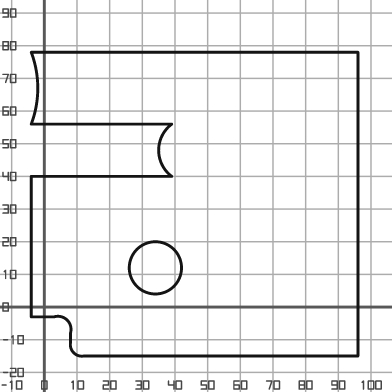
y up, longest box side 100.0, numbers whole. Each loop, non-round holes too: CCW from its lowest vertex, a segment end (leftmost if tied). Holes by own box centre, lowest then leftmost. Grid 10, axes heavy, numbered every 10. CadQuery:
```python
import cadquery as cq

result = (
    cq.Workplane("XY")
    .moveTo(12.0, -15.0)
    .lineTo(96.0, -15.0)
    .lineTo(96.0, 78.0)
    .lineTo(-4.0, 78.0)
    .threePointArc((-2.0, 67.0), (-4.0, 56.0))
    .lineTo(39.0, 56.0)
    .threePointArc((35.0, 48.0), (39.0, 40.0))
    .lineTo(-4.0, 40.0)
    .lineTo(-4.0, -3.0)
    .lineTo(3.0, -3.0)
    .threePointArc((7.0, -4.0), (8.0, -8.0))
    .lineTo(8.0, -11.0)
    .threePointArc((9.0, -14.0), (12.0, -15.0))
    .close()
    .moveTo(34.0, 12.0)
    .circle(8.0)
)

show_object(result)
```